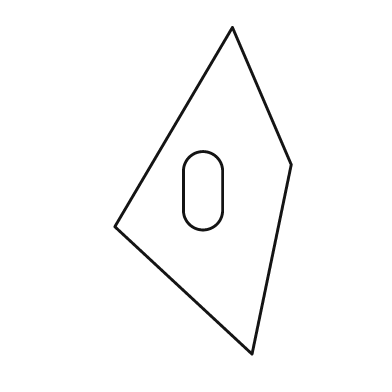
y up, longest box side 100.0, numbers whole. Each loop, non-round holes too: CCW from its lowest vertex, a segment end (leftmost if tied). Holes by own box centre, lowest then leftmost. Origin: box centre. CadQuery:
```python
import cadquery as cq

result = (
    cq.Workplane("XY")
    .moveTo(15.0, -50.0)
    .lineTo(27.0, 8.0)
    .lineTo(9.0, 50.0)
    .lineTo(-27.0, -11.0)
    .close()
    .moveTo(-6.0, -6.0)
    .threePointArc((0.0, -12.0), (6.0, -6.0))
    .lineTo(6.0, 6.0)
    .threePointArc((0.0, 12.0), (-6.0, 6.0))
    .close()
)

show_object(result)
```